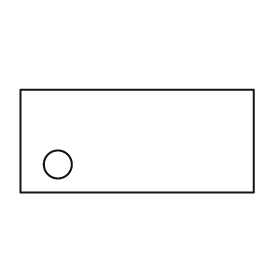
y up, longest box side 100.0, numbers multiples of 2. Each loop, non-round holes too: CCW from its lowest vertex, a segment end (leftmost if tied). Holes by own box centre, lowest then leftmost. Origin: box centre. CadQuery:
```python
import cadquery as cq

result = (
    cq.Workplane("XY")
    .moveTo(-50.0, -22.0)
    .lineTo(50.0, -22.0)
    .lineTo(50.0, 22.0)
    .lineTo(-50.0, 22.0)
    .close()
    .moveTo(-34.0, -10.0)
    .circle(6.0)
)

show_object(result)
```